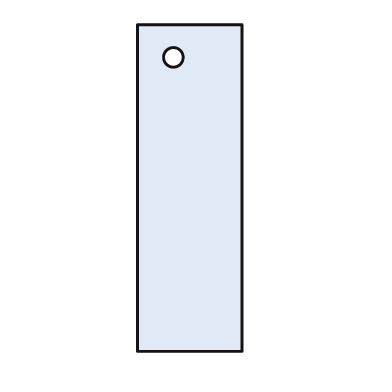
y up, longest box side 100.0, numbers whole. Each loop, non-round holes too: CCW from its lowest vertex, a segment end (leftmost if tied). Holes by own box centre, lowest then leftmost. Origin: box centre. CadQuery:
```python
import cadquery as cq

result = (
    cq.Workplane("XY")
    .moveTo(-16.0, -50.0)
    .lineTo(16.0, -50.0)
    .lineTo(16.0, 50.0)
    .lineTo(-16.0, 50.0)
    .close()
    .moveTo(-5.0, 40.0)
    .circle(3.0)
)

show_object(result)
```